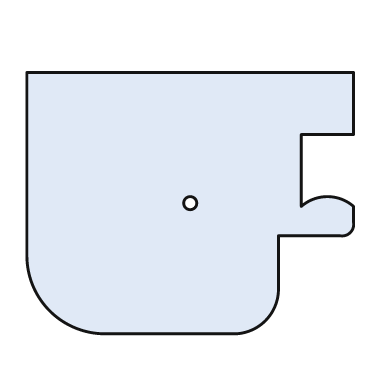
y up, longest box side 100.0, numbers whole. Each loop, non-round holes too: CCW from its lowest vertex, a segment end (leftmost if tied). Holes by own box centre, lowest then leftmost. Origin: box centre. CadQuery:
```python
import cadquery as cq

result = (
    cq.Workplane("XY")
    .moveTo(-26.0, -40.0)
    .lineTo(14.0, -40.0)
    .threePointArc((23.0, -36.0), (27.0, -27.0))
    .lineTo(27.0, -10.0)
    .lineTo(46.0, -10.0)
    .threePointArc((49.0, -9.0), (50.0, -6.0))
    .lineTo(50.0, -1.0)
    .threePointArc((42.0, 2.0), (34.0, -1.0))
    .lineTo(34.0, 21.0)
    .lineTo(50.0, 21.0)
    .lineTo(50.0, 40.0)
    .lineTo(-50.0, 40.0)
    .lineTo(-50.0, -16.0)
    .threePointArc((-43.0, -33.0), (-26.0, -40.0))
    .close()
    .moveTo(0.0, 0.0)
    .circle(2.0)
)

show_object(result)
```